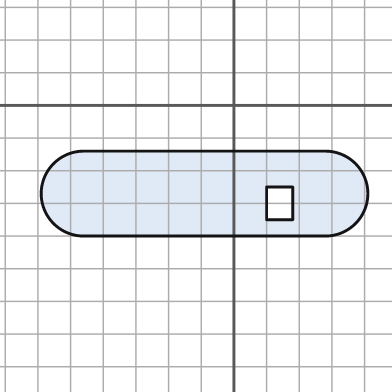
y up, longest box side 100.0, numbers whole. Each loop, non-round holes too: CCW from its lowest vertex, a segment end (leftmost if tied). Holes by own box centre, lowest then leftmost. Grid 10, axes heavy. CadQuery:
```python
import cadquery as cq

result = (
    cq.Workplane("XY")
    .moveTo(-46.0, -40.0)
    .lineTo(28.0, -40.0)
    .threePointArc((41.0, -27.0), (28.0, -14.0))
    .lineTo(-46.0, -14.0)
    .threePointArc((-59.0, -27.0), (-46.0, -40.0))
    .close()
    .moveTo(10.0, -35.0)
    .lineTo(18.0, -35.0)
    .lineTo(18.0, -25.0)
    .lineTo(10.0, -25.0)
    .close()
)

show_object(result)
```